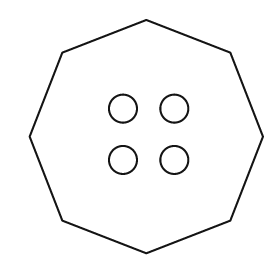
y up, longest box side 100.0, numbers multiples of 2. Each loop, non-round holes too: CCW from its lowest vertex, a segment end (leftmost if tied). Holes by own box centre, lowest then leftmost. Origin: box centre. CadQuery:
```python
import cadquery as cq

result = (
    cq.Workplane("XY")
    .moveTo(0.0, -50.0)
    .lineTo(36.0, -36.0)
    .lineTo(50.0, 0.0)
    .lineTo(36.0, 36.0)
    .lineTo(0.0, 50.0)
    .lineTo(-36.0, 36.0)
    .lineTo(-50.0, 0.0)
    .lineTo(-36.0, -36.0)
    .close()
    .moveTo(-10.0, -10.0)
    .circle(6.0)
    .moveTo(12.0, -10.0)
    .circle(6.0)
    .moveTo(-10.0, 12.0)
    .circle(6.0)
    .moveTo(12.0, 12.0)
    .circle(6.0)
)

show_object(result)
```